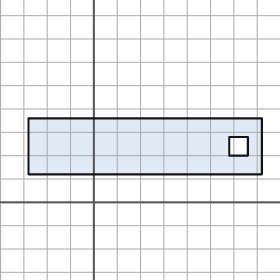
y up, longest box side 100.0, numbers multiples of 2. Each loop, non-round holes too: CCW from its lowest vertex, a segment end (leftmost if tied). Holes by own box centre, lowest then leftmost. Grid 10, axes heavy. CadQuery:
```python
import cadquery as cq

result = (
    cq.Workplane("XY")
    .moveTo(-28.0, 12.0)
    .lineTo(72.0, 12.0)
    .lineTo(72.0, 36.0)
    .lineTo(-28.0, 36.0)
    .close()
    .moveTo(58.0, 20.0)
    .lineTo(66.0, 20.0)
    .lineTo(66.0, 28.0)
    .lineTo(58.0, 28.0)
    .close()
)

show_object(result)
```